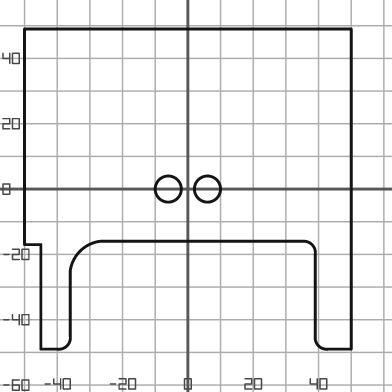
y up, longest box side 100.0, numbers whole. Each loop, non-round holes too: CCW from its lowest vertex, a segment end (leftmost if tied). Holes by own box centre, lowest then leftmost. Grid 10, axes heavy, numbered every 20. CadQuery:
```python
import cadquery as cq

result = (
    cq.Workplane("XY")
    .moveTo(-45.0, -49.0)
    .lineTo(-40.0, -49.0)
    .threePointArc((-37.0, -48.0), (-36.0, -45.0))
    .lineTo(-36.0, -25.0)
    .threePointArc((-33.0, -19.0), (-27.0, -16.0))
    .lineTo(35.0, -16.0)
    .threePointArc((38.0, -17.0), (39.0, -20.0))
    .lineTo(39.0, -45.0)
    .threePointArc((40.0, -48.0), (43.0, -49.0))
    .lineTo(50.0, -49.0)
    .lineTo(50.0, 49.0)
    .lineTo(-50.0, 49.0)
    .lineTo(-50.0, -17.0)
    .lineTo(-45.0, -17.0)
    .close()
    .moveTo(-6.0, 0.0)
    .circle(4.0)
    .moveTo(6.0, 0.0)
    .circle(4.0)
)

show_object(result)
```